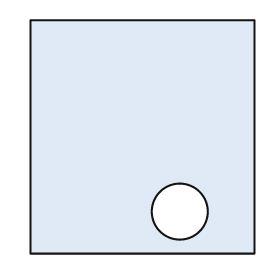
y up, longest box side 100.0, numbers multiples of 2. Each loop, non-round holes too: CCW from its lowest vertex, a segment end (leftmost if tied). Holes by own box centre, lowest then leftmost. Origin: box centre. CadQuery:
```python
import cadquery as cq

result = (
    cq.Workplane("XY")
    .moveTo(-48.0, -50.0)
    .lineTo(48.0, -50.0)
    .lineTo(48.0, 50.0)
    .lineTo(-48.0, 50.0)
    .close()
    .moveTo(16.0, -32.0)
    .circle(12.0)
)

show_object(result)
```